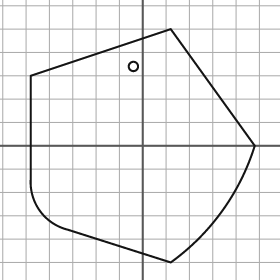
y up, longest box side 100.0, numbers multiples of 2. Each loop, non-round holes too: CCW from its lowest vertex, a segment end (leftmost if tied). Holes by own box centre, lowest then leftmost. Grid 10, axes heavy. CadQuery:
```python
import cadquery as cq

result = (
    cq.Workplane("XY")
    .moveTo(12.0, -50.0)
    .threePointArc((34.0, -28.0), (48.0, 0.0))
    .lineTo(12.0, 50.0)
    .lineTo(-48.0, 30.0)
    .lineTo(-48.0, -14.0)
    .threePointArc((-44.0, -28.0), (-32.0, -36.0))
    .close()
    .moveTo(-4.0, 34.0)
    .circle(2.0)
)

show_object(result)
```